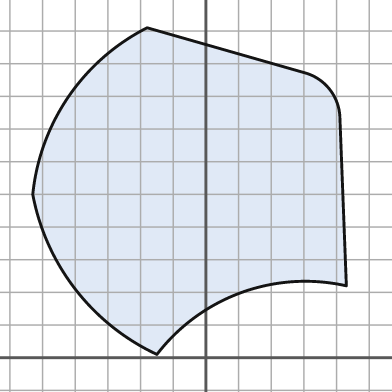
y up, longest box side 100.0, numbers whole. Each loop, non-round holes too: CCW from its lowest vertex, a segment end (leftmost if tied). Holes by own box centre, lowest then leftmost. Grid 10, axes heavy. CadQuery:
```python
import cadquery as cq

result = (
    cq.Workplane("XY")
    .moveTo(-15.0, 1.0)
    .threePointArc((11.0, 20.0), (43.0, 22.0))
    .lineTo(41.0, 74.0)
    .threePointArc((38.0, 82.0), (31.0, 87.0))
    .lineTo(-18.0, 101.0)
    .threePointArc((-42.0, 80.0), (-53.0, 50.0))
    .threePointArc((-40.0, 21.0), (-15.0, 1.0))
    .close()
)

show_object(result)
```